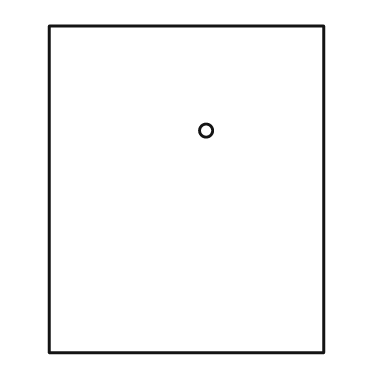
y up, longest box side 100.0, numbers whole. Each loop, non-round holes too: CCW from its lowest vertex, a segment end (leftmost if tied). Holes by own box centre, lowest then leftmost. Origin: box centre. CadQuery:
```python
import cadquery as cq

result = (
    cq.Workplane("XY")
    .moveTo(-42.0, -50.0)
    .lineTo(42.0, -50.0)
    .lineTo(42.0, 50.0)
    .lineTo(-42.0, 50.0)
    .close()
    .moveTo(6.0, 18.0)
    .circle(2.0)
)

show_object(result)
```